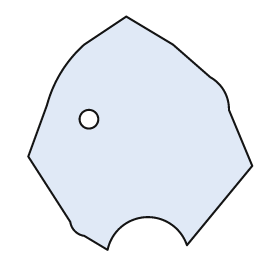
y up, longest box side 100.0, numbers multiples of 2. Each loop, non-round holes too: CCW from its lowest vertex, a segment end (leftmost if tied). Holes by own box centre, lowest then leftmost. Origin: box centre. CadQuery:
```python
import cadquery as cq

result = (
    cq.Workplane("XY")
    .moveTo(-14.0, -50.0)
    .threePointArc((2.0, -36.0), (20.0, -48.0))
    .lineTo(48.0, -14.0)
    .lineTo(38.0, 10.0)
    .threePointArc((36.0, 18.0), (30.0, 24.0))
    .lineTo(14.0, 38.0)
    .lineTo(-6.0, 50.0)
    .lineTo(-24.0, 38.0)
    .threePointArc((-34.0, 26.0), (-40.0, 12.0))
    .lineTo(-48.0, -10.0)
    .lineTo(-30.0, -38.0)
    .threePointArc((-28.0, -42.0), (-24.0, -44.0))
    .close()
    .moveTo(-22.0, 6.0)
    .circle(4.0)
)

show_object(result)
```